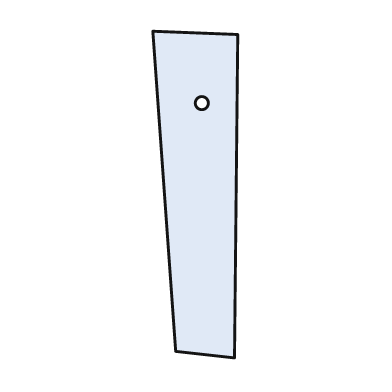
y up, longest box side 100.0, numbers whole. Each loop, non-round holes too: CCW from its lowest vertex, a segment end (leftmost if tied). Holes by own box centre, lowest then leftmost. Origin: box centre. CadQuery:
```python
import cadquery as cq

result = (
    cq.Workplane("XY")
    .moveTo(12.0, -50.0)
    .lineTo(13.0, 49.0)
    .lineTo(-13.0, 50.0)
    .lineTo(-6.0, -48.0)
    .close()
    .moveTo(2.0, 28.0)
    .circle(2.0)
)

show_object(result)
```